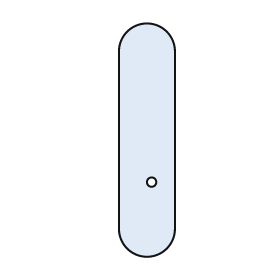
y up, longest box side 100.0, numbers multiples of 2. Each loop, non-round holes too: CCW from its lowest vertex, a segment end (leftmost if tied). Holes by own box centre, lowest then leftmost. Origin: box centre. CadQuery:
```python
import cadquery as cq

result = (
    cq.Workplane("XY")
    .moveTo(-12.0, -38.0)
    .threePointArc((0.0, -50.0), (12.0, -38.0))
    .lineTo(12.0, 38.0)
    .threePointArc((0.0, 50.0), (-12.0, 38.0))
    .close()
    .moveTo(2.0, -18.0)
    .circle(2.0)
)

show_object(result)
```